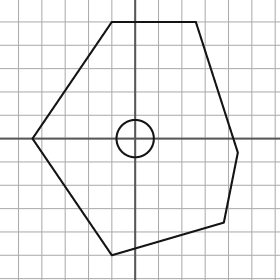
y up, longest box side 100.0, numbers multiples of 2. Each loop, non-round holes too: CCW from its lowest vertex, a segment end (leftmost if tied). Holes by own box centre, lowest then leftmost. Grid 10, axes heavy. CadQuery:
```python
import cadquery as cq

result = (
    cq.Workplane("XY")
    .moveTo(-10.0, -50.0)
    .lineTo(38.0, -36.0)
    .lineTo(44.0, -6.0)
    .lineTo(26.0, 50.0)
    .lineTo(-10.0, 50.0)
    .lineTo(-44.0, 0.0)
    .close()
    .moveTo(0.0, 0.0)
    .circle(8.0)
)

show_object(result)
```